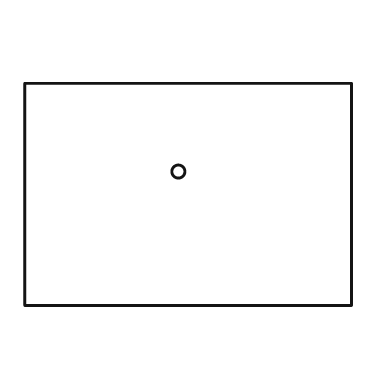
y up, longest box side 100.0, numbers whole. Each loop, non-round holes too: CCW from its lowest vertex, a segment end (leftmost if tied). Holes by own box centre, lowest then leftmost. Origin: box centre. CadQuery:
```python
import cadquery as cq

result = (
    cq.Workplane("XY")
    .moveTo(-50.0, -34.0)
    .lineTo(50.0, -34.0)
    .lineTo(50.0, 34.0)
    .lineTo(-50.0, 34.0)
    .close()
    .moveTo(-3.0, 7.0)
    .circle(2.0)
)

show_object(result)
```